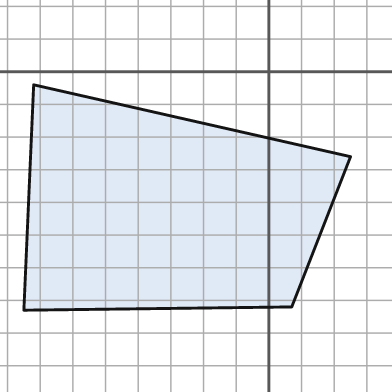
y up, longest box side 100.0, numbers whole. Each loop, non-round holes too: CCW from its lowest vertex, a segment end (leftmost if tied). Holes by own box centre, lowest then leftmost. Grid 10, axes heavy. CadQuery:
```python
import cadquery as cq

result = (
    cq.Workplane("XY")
    .moveTo(-75.0, -73.0)
    .lineTo(7.0, -72.0)
    .lineTo(25.0, -26.0)
    .lineTo(-72.0, -4.0)
    .close()
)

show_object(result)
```